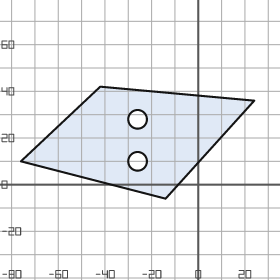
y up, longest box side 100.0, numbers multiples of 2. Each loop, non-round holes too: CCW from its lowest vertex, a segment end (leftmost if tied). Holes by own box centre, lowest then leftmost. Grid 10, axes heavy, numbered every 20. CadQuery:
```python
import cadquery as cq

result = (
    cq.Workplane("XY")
    .moveTo(-14.0, -6.0)
    .lineTo(24.0, 36.0)
    .lineTo(-42.0, 42.0)
    .lineTo(-76.0, 10.0)
    .close()
    .moveTo(-26.0, 10.0)
    .circle(4.0)
    .moveTo(-26.0, 28.0)
    .circle(4.0)
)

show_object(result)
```